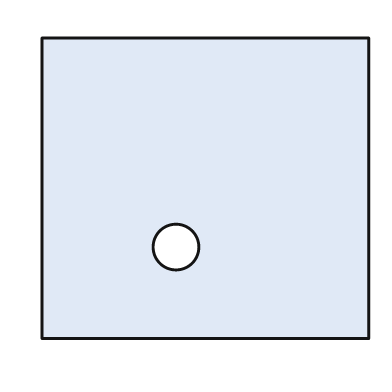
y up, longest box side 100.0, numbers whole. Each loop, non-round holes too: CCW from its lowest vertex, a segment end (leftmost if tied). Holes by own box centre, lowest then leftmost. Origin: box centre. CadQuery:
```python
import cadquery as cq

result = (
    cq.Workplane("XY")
    .moveTo(-50.0, -46.0)
    .lineTo(50.0, -46.0)
    .lineTo(50.0, 46.0)
    .lineTo(-50.0, 46.0)
    .close()
    .moveTo(-9.0, -18.0)
    .circle(7.0)
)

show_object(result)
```